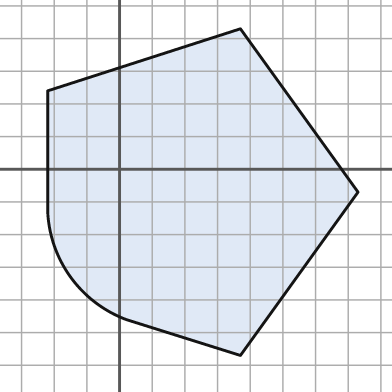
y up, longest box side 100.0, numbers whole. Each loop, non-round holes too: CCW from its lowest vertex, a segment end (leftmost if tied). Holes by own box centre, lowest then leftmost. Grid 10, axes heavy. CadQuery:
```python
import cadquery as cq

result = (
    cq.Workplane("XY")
    .moveTo(37.0, -57.0)
    .lineTo(73.0, -7.0)
    .lineTo(37.0, 43.0)
    .lineTo(-22.0, 24.0)
    .lineTo(-22.0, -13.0)
    .threePointArc((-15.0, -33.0), (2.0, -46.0))
    .close()
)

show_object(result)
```